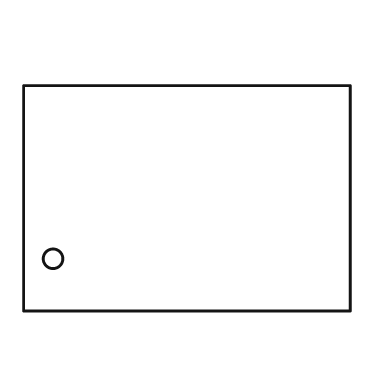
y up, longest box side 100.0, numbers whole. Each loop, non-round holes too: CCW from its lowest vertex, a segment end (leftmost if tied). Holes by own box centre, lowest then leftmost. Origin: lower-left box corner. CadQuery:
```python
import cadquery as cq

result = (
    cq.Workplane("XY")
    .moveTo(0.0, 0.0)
    .lineTo(100.0, 0.0)
    .lineTo(100.0, 69.0)
    .lineTo(0.0, 69.0)
    .close()
    .moveTo(9.0, 16.0)
    .circle(3.0)
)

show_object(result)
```